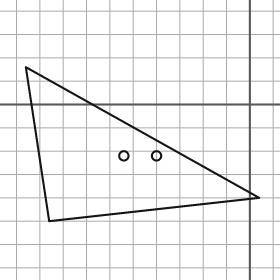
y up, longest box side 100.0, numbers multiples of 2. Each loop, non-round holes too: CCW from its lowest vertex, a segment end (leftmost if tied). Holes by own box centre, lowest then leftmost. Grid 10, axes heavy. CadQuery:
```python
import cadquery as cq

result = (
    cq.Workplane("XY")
    .moveTo(-86.0, -50.0)
    .lineTo(4.0, -40.0)
    .lineTo(-96.0, 16.0)
    .close()
    .moveTo(-54.0, -22.0)
    .circle(2.0)
    .moveTo(-40.0, -22.0)
    .circle(2.0)
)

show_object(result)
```